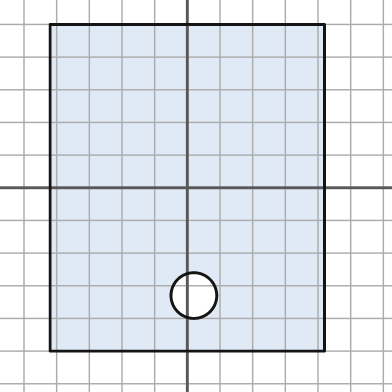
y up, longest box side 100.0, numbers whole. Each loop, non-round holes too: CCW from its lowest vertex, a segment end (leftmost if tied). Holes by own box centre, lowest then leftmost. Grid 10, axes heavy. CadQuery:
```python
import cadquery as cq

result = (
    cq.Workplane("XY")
    .moveTo(-42.0, -50.0)
    .lineTo(42.0, -50.0)
    .lineTo(42.0, 50.0)
    .lineTo(-42.0, 50.0)
    .close()
    .moveTo(2.0, -33.0)
    .circle(7.0)
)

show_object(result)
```